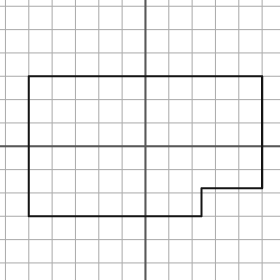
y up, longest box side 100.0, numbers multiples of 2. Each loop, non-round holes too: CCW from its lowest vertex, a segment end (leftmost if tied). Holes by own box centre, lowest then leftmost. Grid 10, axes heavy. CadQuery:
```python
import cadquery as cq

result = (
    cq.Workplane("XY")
    .moveTo(-50.0, -30.0)
    .lineTo(24.0, -30.0)
    .lineTo(24.0, -18.0)
    .lineTo(50.0, -18.0)
    .lineTo(50.0, 30.0)
    .lineTo(-50.0, 30.0)
    .close()
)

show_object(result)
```